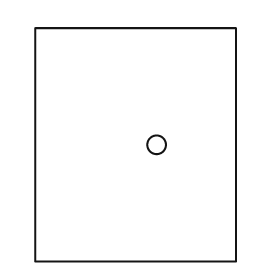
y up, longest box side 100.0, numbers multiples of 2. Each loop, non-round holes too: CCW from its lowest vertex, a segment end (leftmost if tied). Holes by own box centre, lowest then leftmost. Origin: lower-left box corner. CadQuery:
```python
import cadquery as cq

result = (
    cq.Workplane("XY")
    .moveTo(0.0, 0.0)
    .lineTo(86.0, 0.0)
    .lineTo(86.0, 100.0)
    .lineTo(0.0, 100.0)
    .close()
    .moveTo(52.0, 50.0)
    .circle(4.0)
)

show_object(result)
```